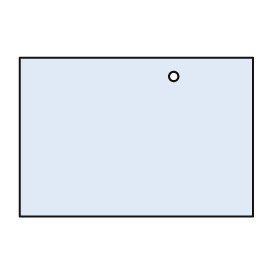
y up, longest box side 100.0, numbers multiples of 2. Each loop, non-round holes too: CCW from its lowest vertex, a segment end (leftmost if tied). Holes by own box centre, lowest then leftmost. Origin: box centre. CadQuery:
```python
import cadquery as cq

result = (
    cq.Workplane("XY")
    .moveTo(-50.0, -34.0)
    .lineTo(50.0, -34.0)
    .lineTo(50.0, 34.0)
    .lineTo(-50.0, 34.0)
    .close()
    .moveTo(16.0, 26.0)
    .circle(2.0)
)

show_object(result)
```